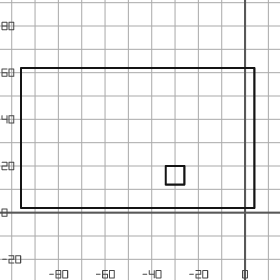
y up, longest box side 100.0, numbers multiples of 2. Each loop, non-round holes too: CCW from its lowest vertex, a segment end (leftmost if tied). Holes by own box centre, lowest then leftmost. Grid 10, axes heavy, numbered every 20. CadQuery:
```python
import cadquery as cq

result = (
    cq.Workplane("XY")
    .moveTo(-96.0, 2.0)
    .lineTo(4.0, 2.0)
    .lineTo(4.0, 62.0)
    .lineTo(-96.0, 62.0)
    .close()
    .moveTo(-34.0, 12.0)
    .lineTo(-26.0, 12.0)
    .lineTo(-26.0, 20.0)
    .lineTo(-34.0, 20.0)
    .close()
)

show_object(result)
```